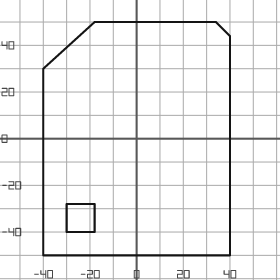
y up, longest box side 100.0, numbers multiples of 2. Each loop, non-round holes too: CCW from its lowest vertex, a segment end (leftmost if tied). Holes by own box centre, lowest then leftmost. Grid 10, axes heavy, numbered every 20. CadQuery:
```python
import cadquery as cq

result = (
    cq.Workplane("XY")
    .moveTo(-40.0, -50.0)
    .lineTo(40.0, -50.0)
    .lineTo(40.0, 44.0)
    .lineTo(34.0, 50.0)
    .lineTo(-18.0, 50.0)
    .lineTo(-40.0, 30.0)
    .close()
    .moveTo(-30.0, -40.0)
    .lineTo(-18.0, -40.0)
    .lineTo(-18.0, -28.0)
    .lineTo(-30.0, -28.0)
    .close()
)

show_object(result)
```